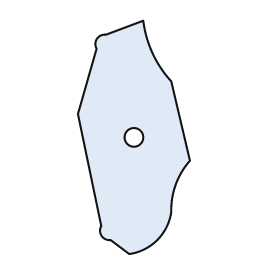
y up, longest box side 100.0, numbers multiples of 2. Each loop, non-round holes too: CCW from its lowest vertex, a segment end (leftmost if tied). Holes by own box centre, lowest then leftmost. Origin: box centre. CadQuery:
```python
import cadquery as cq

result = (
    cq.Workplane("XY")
    .moveTo(-2.0, -50.0)
    .threePointArc((10.0, -44.0), (16.0, -32.0))
    .threePointArc((18.0, -20.0), (24.0, -10.0))
    .lineTo(16.0, 24.0)
    .threePointArc((8.0, 36.0), (4.0, 50.0))
    .lineTo(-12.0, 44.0)
    .threePointArc((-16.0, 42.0), (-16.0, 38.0))
    .lineTo(-24.0, 10.0)
    .lineTo(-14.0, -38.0)
    .threePointArc((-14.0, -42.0), (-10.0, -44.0))
    .close()
    .moveTo(0.0, 0.0)
    .circle(4.0)
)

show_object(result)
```